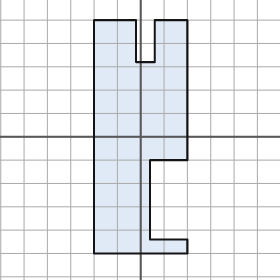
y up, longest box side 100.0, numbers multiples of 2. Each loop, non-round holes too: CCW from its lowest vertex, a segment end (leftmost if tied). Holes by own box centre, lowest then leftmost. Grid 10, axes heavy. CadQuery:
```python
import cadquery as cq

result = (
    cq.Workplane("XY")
    .moveTo(-20.0, -50.0)
    .lineTo(20.0, -50.0)
    .lineTo(20.0, -44.0)
    .lineTo(4.0, -44.0)
    .lineTo(4.0, -10.0)
    .lineTo(20.0, -10.0)
    .lineTo(20.0, 50.0)
    .lineTo(6.0, 50.0)
    .lineTo(6.0, 32.0)
    .lineTo(-2.0, 32.0)
    .lineTo(-2.0, 50.0)
    .lineTo(-20.0, 50.0)
    .close()
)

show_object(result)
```